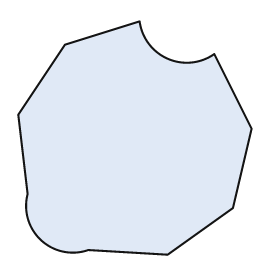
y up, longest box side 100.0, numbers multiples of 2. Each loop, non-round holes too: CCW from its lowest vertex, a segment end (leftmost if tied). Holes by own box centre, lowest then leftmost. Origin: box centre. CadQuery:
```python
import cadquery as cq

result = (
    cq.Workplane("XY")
    .moveTo(14.0, -50.0)
    .lineTo(42.0, -30.0)
    .lineTo(50.0, 4.0)
    .lineTo(34.0, 36.0)
    .threePointArc((14.0, 34.0), (2.0, 50.0))
    .lineTo(-30.0, 40.0)
    .lineTo(-50.0, 10.0)
    .lineTo(-46.0, -24.0)
    .threePointArc((-40.0, -44.0), (-20.0, -48.0))
    .close()
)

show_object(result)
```